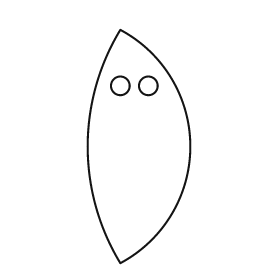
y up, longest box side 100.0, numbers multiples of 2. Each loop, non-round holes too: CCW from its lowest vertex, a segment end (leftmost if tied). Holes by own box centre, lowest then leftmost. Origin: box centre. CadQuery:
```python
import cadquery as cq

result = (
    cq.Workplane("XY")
    .moveTo(-8.0, -50.0)
    .threePointArc((22.0, 0.0), (-8.0, 50.0))
    .threePointArc((-22.0, 0.0), (-8.0, -50.0))
    .close()
    .moveTo(-8.0, 26.0)
    .circle(4.0)
    .moveTo(4.0, 26.0)
    .circle(4.0)
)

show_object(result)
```